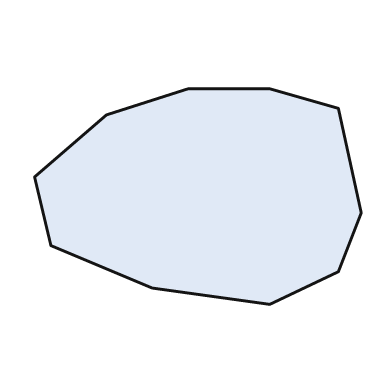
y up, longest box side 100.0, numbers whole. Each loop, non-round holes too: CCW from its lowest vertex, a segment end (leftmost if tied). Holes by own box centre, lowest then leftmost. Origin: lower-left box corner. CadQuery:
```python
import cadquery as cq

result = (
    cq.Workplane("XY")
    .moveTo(72.0, 0.0)
    .lineTo(93.0, 10.0)
    .lineTo(100.0, 28.0)
    .lineTo(93.0, 60.0)
    .lineTo(72.0, 66.0)
    .lineTo(47.0, 66.0)
    .lineTo(22.0, 58.0)
    .lineTo(0.0, 39.0)
    .lineTo(5.0, 18.0)
    .lineTo(36.0, 5.0)
    .close()
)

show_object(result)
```